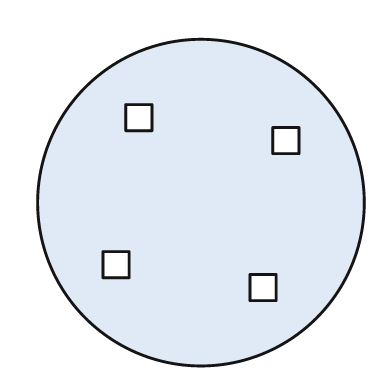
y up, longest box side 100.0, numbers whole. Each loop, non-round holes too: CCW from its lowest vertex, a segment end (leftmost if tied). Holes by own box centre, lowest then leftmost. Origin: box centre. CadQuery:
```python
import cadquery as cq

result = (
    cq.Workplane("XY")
    .moveTo(0.0, 0.0)
    .circle(50.0)
    .moveTo(15.0, -30.0)
    .lineTo(23.0, -30.0)
    .lineTo(23.0, -22.0)
    .lineTo(15.0, -22.0)
    .close()
    .moveTo(-30.0, -23.0)
    .lineTo(-22.0, -23.0)
    .lineTo(-22.0, -15.0)
    .lineTo(-30.0, -15.0)
    .close()
    .moveTo(22.0, 15.0)
    .lineTo(30.0, 15.0)
    .lineTo(30.0, 23.0)
    .lineTo(22.0, 23.0)
    .close()
    .moveTo(-23.0, 22.0)
    .lineTo(-15.0, 22.0)
    .lineTo(-15.0, 30.0)
    .lineTo(-23.0, 30.0)
    .close()
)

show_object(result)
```